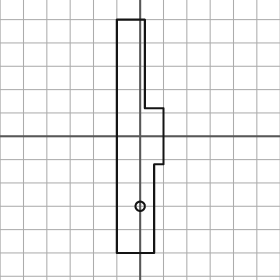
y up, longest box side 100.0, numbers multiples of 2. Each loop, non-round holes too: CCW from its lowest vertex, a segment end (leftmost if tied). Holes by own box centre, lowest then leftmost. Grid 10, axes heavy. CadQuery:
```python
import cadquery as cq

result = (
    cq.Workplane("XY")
    .moveTo(-10.0, -50.0)
    .lineTo(6.0, -50.0)
    .lineTo(6.0, -12.0)
    .lineTo(10.0, -12.0)
    .lineTo(10.0, 12.0)
    .lineTo(2.0, 12.0)
    .lineTo(2.0, 50.0)
    .lineTo(-10.0, 50.0)
    .close()
    .moveTo(0.0, -30.0)
    .circle(2.0)
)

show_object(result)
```